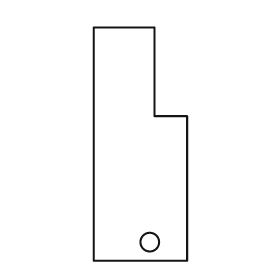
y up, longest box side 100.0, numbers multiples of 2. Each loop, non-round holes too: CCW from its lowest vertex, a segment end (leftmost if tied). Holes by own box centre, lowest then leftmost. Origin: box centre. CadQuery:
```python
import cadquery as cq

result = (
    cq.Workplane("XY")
    .moveTo(-20.0, -50.0)
    .lineTo(20.0, -50.0)
    .lineTo(20.0, 12.0)
    .lineTo(6.0, 12.0)
    .lineTo(6.0, 50.0)
    .lineTo(-20.0, 50.0)
    .close()
    .moveTo(4.0, -42.0)
    .circle(4.0)
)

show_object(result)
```